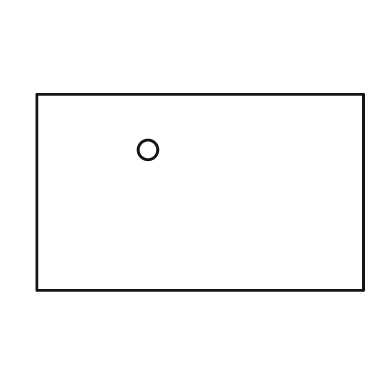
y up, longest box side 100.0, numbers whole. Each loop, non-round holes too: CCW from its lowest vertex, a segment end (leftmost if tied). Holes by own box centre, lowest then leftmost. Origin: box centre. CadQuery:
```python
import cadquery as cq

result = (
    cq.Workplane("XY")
    .moveTo(-50.0, -30.0)
    .lineTo(50.0, -30.0)
    .lineTo(50.0, 30.0)
    .lineTo(-50.0, 30.0)
    .close()
    .moveTo(-16.0, 13.0)
    .circle(3.0)
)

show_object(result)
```